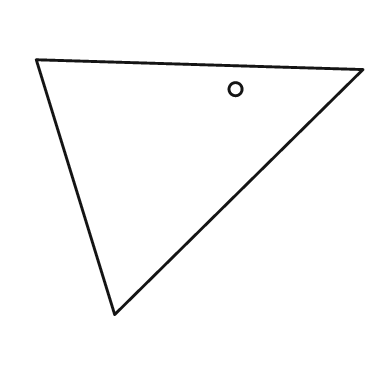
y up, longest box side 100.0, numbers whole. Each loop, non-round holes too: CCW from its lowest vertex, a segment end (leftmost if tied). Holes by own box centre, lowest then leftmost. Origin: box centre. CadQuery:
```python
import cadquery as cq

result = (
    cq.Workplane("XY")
    .moveTo(-26.0, -39.0)
    .lineTo(50.0, 36.0)
    .lineTo(-50.0, 39.0)
    .close()
    .moveTo(11.0, 30.0)
    .circle(2.0)
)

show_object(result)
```